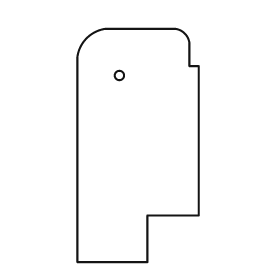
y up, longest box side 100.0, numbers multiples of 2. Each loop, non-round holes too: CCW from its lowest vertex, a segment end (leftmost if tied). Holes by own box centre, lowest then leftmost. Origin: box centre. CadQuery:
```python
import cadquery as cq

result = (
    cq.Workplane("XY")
    .moveTo(-26.0, -50.0)
    .lineTo(4.0, -50.0)
    .lineTo(4.0, -30.0)
    .lineTo(26.0, -30.0)
    .lineTo(26.0, 34.0)
    .lineTo(22.0, 34.0)
    .lineTo(22.0, 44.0)
    .threePointArc((20.0, 48.0), (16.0, 50.0))
    .lineTo(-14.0, 50.0)
    .threePointArc((-22.0, 46.0), (-26.0, 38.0))
    .close()
    .moveTo(-8.0, 30.0)
    .circle(2.0)
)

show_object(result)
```